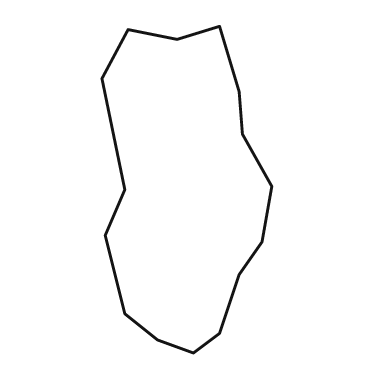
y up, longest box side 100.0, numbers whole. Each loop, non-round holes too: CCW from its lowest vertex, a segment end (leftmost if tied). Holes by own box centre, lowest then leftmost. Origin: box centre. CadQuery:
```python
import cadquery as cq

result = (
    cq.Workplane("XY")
    .moveTo(2.0, -50.0)
    .lineTo(10.0, -44.0)
    .lineTo(16.0, -26.0)
    .lineTo(23.0, -16.0)
    .lineTo(26.0, 1.0)
    .lineTo(17.0, 17.0)
    .lineTo(16.0, 30.0)
    .lineTo(10.0, 50.0)
    .lineTo(-3.0, 46.0)
    .lineTo(-18.0, 49.0)
    .lineTo(-26.0, 34.0)
    .lineTo(-19.0, 0.0)
    .lineTo(-25.0, -14.0)
    .lineTo(-19.0, -38.0)
    .lineTo(-9.0, -46.0)
    .close()
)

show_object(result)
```